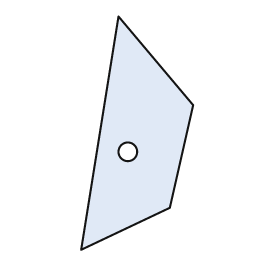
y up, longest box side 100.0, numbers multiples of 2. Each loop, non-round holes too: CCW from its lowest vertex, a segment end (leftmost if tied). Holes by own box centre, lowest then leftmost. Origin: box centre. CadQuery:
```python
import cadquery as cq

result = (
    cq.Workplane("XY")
    .moveTo(-24.0, -50.0)
    .lineTo(14.0, -32.0)
    .lineTo(24.0, 12.0)
    .lineTo(-8.0, 50.0)
    .close()
    .moveTo(-4.0, -8.0)
    .circle(4.0)
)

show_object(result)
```